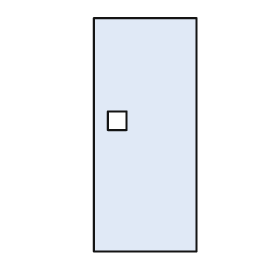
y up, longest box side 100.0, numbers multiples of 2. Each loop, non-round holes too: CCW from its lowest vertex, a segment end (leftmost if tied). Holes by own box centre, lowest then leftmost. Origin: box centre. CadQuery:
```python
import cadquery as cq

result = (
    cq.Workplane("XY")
    .moveTo(-22.0, -50.0)
    .lineTo(22.0, -50.0)
    .lineTo(22.0, 50.0)
    .lineTo(-22.0, 50.0)
    .close()
    .moveTo(-16.0, 2.0)
    .lineTo(-8.0, 2.0)
    .lineTo(-8.0, 10.0)
    .lineTo(-16.0, 10.0)
    .close()
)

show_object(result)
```